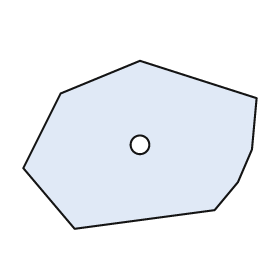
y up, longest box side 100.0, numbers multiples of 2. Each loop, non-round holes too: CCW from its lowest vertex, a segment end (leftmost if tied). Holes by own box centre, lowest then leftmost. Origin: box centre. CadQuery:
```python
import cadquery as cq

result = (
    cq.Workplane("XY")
    .moveTo(-28.0, -36.0)
    .lineTo(32.0, -28.0)
    .lineTo(42.0, -16.0)
    .lineTo(48.0, -2.0)
    .lineTo(50.0, 20.0)
    .lineTo(0.0, 36.0)
    .lineTo(-34.0, 22.0)
    .lineTo(-50.0, -10.0)
    .close()
    .moveTo(0.0, 0.0)
    .circle(4.0)
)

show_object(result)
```